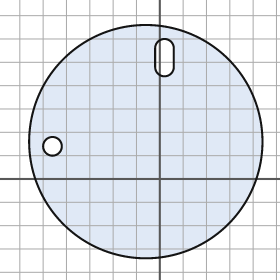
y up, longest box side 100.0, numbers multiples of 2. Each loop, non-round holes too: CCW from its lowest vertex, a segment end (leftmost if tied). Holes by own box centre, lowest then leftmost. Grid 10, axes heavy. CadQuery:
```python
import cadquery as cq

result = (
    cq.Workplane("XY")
    .moveTo(-6.0, 16.0)
    .circle(50.0)
    .moveTo(-46.0, 14.0)
    .circle(4.0)
    .moveTo(-2.0, 48.0)
    .threePointArc((2.0, 44.0), (6.0, 48.0))
    .lineTo(6.0, 56.0)
    .threePointArc((2.0, 60.0), (-2.0, 56.0))
    .close()
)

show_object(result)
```